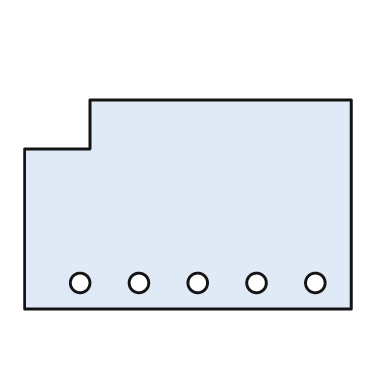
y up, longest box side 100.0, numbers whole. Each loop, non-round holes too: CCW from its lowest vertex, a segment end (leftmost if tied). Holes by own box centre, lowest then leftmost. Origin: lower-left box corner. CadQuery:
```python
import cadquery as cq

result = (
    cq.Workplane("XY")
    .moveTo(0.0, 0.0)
    .lineTo(100.0, 0.0)
    .lineTo(100.0, 64.0)
    .lineTo(20.0, 64.0)
    .lineTo(20.0, 49.0)
    .lineTo(0.0, 49.0)
    .close()
    .moveTo(17.0, 8.0)
    .circle(3.0)
    .moveTo(35.0, 8.0)
    .circle(3.0)
    .moveTo(53.0, 8.0)
    .circle(3.0)
    .moveTo(71.0, 8.0)
    .circle(3.0)
    .moveTo(89.0, 8.0)
    .circle(3.0)
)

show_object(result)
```